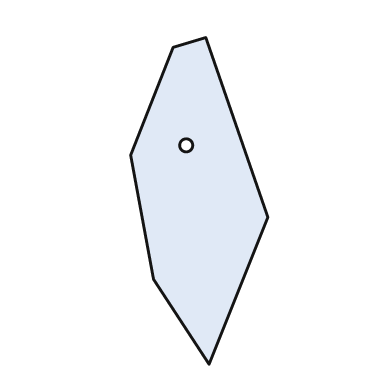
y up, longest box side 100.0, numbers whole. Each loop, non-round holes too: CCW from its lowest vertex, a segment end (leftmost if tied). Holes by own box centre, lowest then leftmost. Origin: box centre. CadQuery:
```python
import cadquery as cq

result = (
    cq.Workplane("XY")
    .moveTo(3.0, -50.0)
    .lineTo(21.0, -5.0)
    .lineTo(2.0, 50.0)
    .lineTo(-8.0, 47.0)
    .lineTo(-21.0, 14.0)
    .lineTo(-14.0, -24.0)
    .close()
    .moveTo(-4.0, 17.0)
    .circle(2.0)
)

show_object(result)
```